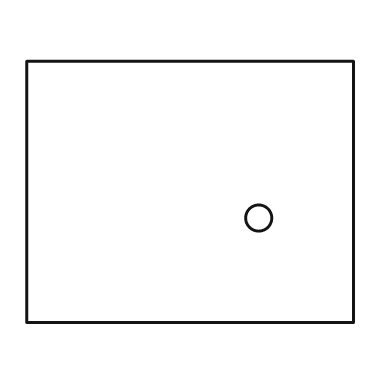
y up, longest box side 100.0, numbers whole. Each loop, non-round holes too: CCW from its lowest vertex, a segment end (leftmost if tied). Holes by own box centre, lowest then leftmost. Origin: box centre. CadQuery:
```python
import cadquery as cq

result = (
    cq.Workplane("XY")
    .moveTo(-50.0, -40.0)
    .lineTo(50.0, -40.0)
    .lineTo(50.0, 40.0)
    .lineTo(-50.0, 40.0)
    .close()
    .moveTo(21.0, -8.0)
    .circle(4.0)
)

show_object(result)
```